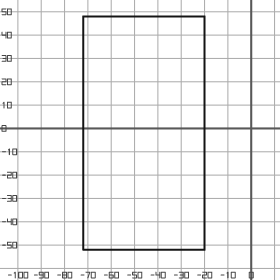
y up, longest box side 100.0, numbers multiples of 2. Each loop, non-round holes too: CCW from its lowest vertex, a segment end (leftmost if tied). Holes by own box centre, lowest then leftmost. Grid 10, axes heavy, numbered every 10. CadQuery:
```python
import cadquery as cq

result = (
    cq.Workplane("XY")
    .moveTo(-72.0, -52.0)
    .lineTo(-20.0, -52.0)
    .lineTo(-20.0, 48.0)
    .lineTo(-72.0, 48.0)
    .close()
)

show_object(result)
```